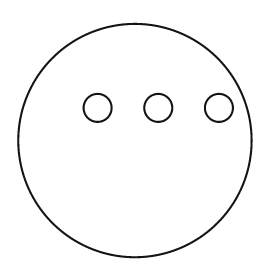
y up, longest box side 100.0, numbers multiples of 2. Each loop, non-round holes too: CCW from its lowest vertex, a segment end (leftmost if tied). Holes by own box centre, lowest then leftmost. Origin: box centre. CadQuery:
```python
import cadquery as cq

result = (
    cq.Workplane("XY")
    .moveTo(0.0, 0.0)
    .circle(50.0)
    .moveTo(-16.0, 14.0)
    .circle(6.0)
    .moveTo(10.0, 14.0)
    .circle(6.0)
    .moveTo(36.0, 14.0)
    .circle(6.0)
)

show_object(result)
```